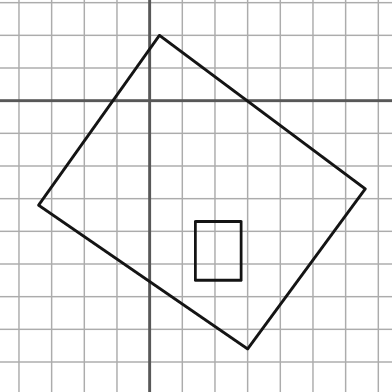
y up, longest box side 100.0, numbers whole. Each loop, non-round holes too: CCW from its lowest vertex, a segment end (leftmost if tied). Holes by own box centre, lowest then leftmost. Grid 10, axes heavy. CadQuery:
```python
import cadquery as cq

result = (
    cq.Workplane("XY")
    .moveTo(30.0, -76.0)
    .lineTo(66.0, -27.0)
    .lineTo(3.0, 20.0)
    .lineTo(-34.0, -32.0)
    .close()
    .moveTo(14.0, -55.0)
    .lineTo(28.0, -55.0)
    .lineTo(28.0, -37.0)
    .lineTo(14.0, -37.0)
    .close()
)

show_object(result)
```